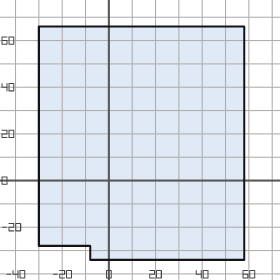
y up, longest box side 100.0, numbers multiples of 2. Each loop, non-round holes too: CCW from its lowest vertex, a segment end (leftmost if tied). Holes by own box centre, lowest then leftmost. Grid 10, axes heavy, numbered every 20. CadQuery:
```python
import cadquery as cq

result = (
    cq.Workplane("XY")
    .moveTo(-8.0, -34.0)
    .lineTo(58.0, -34.0)
    .lineTo(58.0, 66.0)
    .lineTo(-30.0, 66.0)
    .lineTo(-30.0, -28.0)
    .lineTo(-8.0, -28.0)
    .close()
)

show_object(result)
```